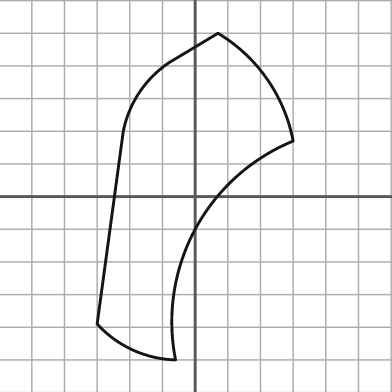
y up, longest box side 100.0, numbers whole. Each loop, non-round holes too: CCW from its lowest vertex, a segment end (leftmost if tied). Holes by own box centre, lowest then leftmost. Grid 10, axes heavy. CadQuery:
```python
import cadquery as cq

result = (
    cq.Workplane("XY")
    .moveTo(-6.0, -50.0)
    .threePointArc((0.0, -10.0), (30.0, 17.0))
    .threePointArc((22.0, 36.0), (7.0, 50.0))
    .lineTo(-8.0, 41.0)
    .threePointArc((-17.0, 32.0), (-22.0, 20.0))
    .lineTo(-30.0, -39.0)
    .threePointArc((-19.0, -47.0), (-6.0, -50.0))
    .close()
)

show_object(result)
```